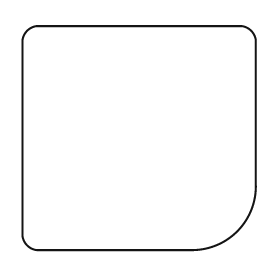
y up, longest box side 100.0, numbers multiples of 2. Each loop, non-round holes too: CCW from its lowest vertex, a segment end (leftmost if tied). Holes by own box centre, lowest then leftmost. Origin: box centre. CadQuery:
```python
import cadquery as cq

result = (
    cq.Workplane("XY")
    .moveTo(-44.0, -48.0)
    .lineTo(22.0, -48.0)
    .threePointArc((42.0, -40.0), (50.0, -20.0))
    .lineTo(50.0, 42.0)
    .threePointArc((48.0, 46.0), (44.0, 48.0))
    .lineTo(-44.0, 48.0)
    .threePointArc((-48.0, 46.0), (-50.0, 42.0))
    .lineTo(-50.0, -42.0)
    .threePointArc((-48.0, -46.0), (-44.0, -48.0))
    .close()
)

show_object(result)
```